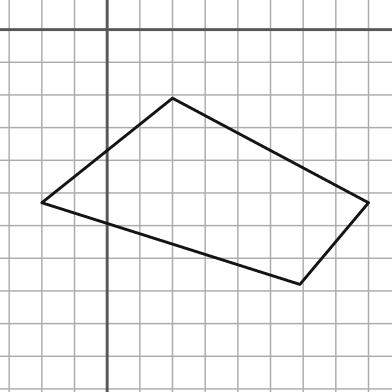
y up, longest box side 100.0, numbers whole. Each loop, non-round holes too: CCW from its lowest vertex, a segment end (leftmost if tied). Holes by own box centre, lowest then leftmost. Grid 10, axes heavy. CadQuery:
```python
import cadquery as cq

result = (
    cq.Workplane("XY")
    .moveTo(59.0, -78.0)
    .lineTo(80.0, -53.0)
    .lineTo(20.0, -21.0)
    .lineTo(-20.0, -53.0)
    .close()
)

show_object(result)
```